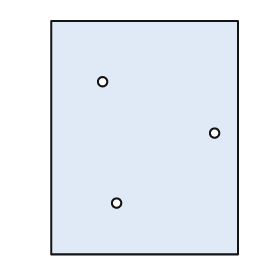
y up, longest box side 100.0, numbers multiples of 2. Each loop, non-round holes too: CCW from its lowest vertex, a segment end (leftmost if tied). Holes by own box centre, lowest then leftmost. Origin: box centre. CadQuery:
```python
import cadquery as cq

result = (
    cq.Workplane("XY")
    .moveTo(-40.0, -50.0)
    .lineTo(40.0, -50.0)
    .lineTo(40.0, 50.0)
    .lineTo(-40.0, 50.0)
    .close()
    .moveTo(-12.0, -28.0)
    .circle(2.0)
    .moveTo(30.0, 2.0)
    .circle(2.0)
    .moveTo(-18.0, 24.0)
    .circle(2.0)
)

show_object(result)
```